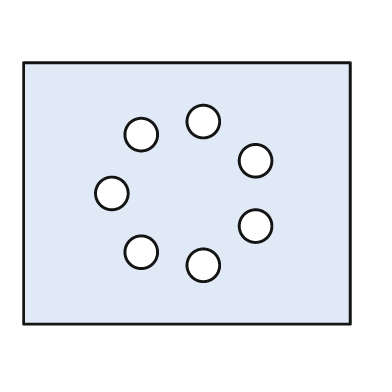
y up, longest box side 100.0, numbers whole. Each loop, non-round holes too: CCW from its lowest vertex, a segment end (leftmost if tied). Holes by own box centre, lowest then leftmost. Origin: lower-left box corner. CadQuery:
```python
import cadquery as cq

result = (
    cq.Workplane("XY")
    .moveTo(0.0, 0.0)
    .lineTo(100.0, 0.0)
    .lineTo(100.0, 80.0)
    .lineTo(0.0, 80.0)
    .close()
    .moveTo(55.0, 18.0)
    .circle(5.0)
    .moveTo(36.0, 22.0)
    .circle(5.0)
    .moveTo(71.0, 30.0)
    .circle(5.0)
    .moveTo(27.0, 40.0)
    .circle(5.0)
    .moveTo(71.0, 50.0)
    .circle(5.0)
    .moveTo(36.0, 58.0)
    .circle(5.0)
    .moveTo(55.0, 62.0)
    .circle(5.0)
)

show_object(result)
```